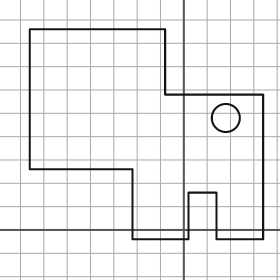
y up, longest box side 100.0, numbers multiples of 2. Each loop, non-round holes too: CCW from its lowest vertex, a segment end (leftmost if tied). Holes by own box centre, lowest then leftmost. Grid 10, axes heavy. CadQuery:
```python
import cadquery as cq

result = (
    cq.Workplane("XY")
    .moveTo(-22.0, -4.0)
    .lineTo(2.0, -4.0)
    .lineTo(2.0, 16.0)
    .lineTo(14.0, 16.0)
    .lineTo(14.0, -4.0)
    .lineTo(34.0, -4.0)
    .lineTo(34.0, 58.0)
    .lineTo(-8.0, 58.0)
    .lineTo(-8.0, 86.0)
    .lineTo(-66.0, 86.0)
    .lineTo(-66.0, 26.0)
    .lineTo(-22.0, 26.0)
    .close()
    .moveTo(18.0, 48.0)
    .circle(6.0)
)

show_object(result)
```